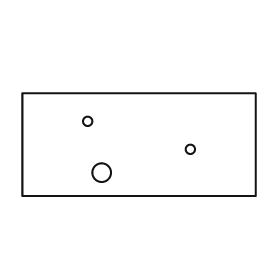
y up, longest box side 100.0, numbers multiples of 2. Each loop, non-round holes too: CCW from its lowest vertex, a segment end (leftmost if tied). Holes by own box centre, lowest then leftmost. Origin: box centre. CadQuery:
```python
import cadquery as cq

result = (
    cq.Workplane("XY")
    .moveTo(-50.0, -22.0)
    .lineTo(50.0, -22.0)
    .lineTo(50.0, 22.0)
    .lineTo(-50.0, 22.0)
    .close()
    .moveTo(-16.0, -12.0)
    .circle(4.0)
    .moveTo(22.0, -2.0)
    .circle(2.0)
    .moveTo(-22.0, 10.0)
    .circle(2.0)
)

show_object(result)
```